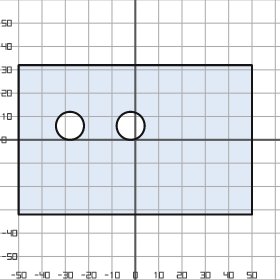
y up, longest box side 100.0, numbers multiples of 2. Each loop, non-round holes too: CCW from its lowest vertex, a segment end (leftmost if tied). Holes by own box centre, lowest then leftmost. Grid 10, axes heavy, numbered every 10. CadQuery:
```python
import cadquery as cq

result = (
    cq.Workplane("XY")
    .moveTo(-50.0, -32.0)
    .lineTo(50.0, -32.0)
    .lineTo(50.0, 32.0)
    .lineTo(-50.0, 32.0)
    .close()
    .moveTo(-28.0, 6.0)
    .circle(6.0)
    .moveTo(-2.0, 6.0)
    .circle(6.0)
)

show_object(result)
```